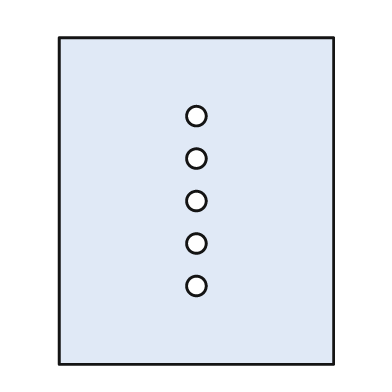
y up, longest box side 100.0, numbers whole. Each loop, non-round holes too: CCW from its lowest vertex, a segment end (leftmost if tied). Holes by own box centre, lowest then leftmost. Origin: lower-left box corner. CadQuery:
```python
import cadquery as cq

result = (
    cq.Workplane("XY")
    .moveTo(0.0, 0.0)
    .lineTo(84.0, 0.0)
    .lineTo(84.0, 100.0)
    .lineTo(0.0, 100.0)
    .close()
    .moveTo(42.0, 24.0)
    .circle(3.0)
    .moveTo(42.0, 37.0)
    .circle(3.0)
    .moveTo(42.0, 50.0)
    .circle(3.0)
    .moveTo(42.0, 63.0)
    .circle(3.0)
    .moveTo(42.0, 76.0)
    .circle(3.0)
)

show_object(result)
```